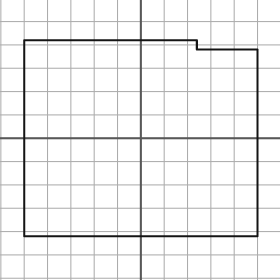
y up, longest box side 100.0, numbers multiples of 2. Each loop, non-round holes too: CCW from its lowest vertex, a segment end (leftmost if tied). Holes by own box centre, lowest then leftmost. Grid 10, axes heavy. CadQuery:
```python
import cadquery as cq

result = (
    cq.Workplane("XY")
    .moveTo(-50.0, -42.0)
    .lineTo(50.0, -42.0)
    .lineTo(50.0, 38.0)
    .lineTo(24.0, 38.0)
    .lineTo(24.0, 42.0)
    .lineTo(-50.0, 42.0)
    .close()
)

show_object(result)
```